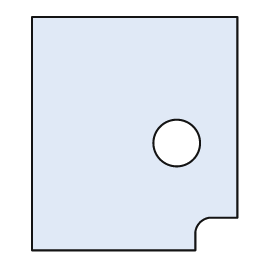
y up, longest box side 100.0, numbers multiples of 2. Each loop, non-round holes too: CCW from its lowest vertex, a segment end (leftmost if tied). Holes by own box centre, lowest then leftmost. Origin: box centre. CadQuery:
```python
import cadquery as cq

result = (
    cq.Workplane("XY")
    .moveTo(-44.0, -50.0)
    .lineTo(26.0, -50.0)
    .lineTo(26.0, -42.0)
    .threePointArc((28.0, -38.0), (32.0, -36.0))
    .lineTo(44.0, -36.0)
    .lineTo(44.0, 50.0)
    .lineTo(-44.0, 50.0)
    .close()
    .moveTo(18.0, -4.0)
    .circle(10.0)
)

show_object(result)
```